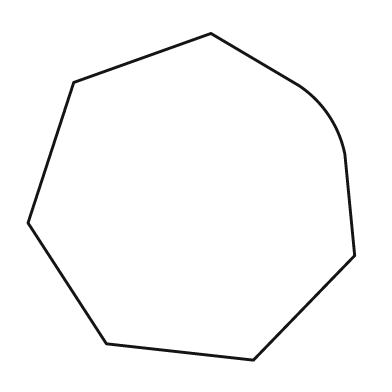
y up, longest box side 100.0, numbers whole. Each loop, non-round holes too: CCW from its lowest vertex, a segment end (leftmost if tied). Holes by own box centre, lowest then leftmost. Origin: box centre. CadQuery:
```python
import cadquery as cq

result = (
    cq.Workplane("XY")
    .moveTo(19.0, -50.0)
    .lineTo(50.0, -18.0)
    .lineTo(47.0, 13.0)
    .threePointArc((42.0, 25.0), (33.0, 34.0))
    .lineTo(6.0, 50.0)
    .lineTo(-36.0, 35.0)
    .lineTo(-50.0, -8.0)
    .lineTo(-26.0, -45.0)
    .close()
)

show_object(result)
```